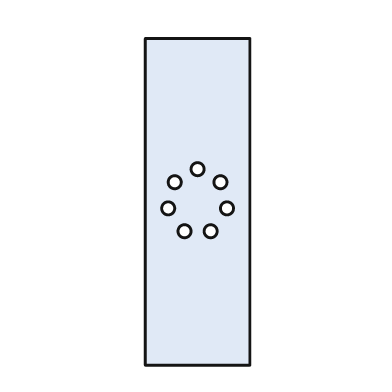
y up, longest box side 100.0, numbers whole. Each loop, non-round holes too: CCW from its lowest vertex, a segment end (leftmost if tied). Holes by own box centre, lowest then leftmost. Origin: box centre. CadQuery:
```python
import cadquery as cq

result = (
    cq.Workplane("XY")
    .moveTo(-16.0, -50.0)
    .lineTo(16.0, -50.0)
    .lineTo(16.0, 50.0)
    .lineTo(-16.0, 50.0)
    .close()
    .moveTo(-4.0, -9.0)
    .circle(2.0)
    .moveTo(4.0, -9.0)
    .circle(2.0)
    .moveTo(-9.0, -2.0)
    .circle(2.0)
    .moveTo(9.0, -2.0)
    .circle(2.0)
    .moveTo(-7.0, 6.0)
    .circle(2.0)
    .moveTo(7.0, 6.0)
    .circle(2.0)
    .moveTo(0.0, 10.0)
    .circle(2.0)
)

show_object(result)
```